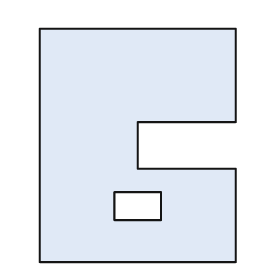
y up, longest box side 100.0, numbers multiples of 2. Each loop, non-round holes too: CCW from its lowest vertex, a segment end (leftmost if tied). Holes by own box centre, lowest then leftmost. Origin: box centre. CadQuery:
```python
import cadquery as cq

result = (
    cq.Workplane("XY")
    .moveTo(-42.0, -50.0)
    .lineTo(42.0, -50.0)
    .lineTo(42.0, -10.0)
    .lineTo(0.0, -10.0)
    .lineTo(0.0, 10.0)
    .lineTo(42.0, 10.0)
    .lineTo(42.0, 50.0)
    .lineTo(-42.0, 50.0)
    .close()
    .moveTo(-10.0, -32.0)
    .lineTo(10.0, -32.0)
    .lineTo(10.0, -20.0)
    .lineTo(-10.0, -20.0)
    .close()
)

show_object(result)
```